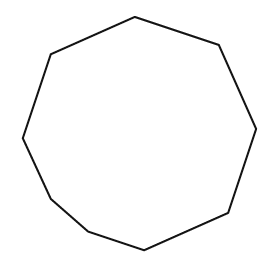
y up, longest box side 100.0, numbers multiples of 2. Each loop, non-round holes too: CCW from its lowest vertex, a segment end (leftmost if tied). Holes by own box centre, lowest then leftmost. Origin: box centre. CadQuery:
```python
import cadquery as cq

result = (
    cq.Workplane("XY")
    .moveTo(2.0, -50.0)
    .lineTo(38.0, -34.0)
    .lineTo(50.0, 2.0)
    .lineTo(34.0, 38.0)
    .lineTo(-2.0, 50.0)
    .lineTo(-38.0, 34.0)
    .lineTo(-50.0, -2.0)
    .lineTo(-38.0, -28.0)
    .lineTo(-22.0, -42.0)
    .close()
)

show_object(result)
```